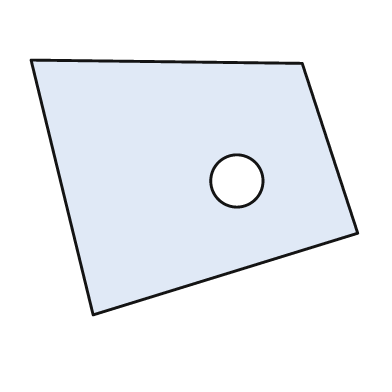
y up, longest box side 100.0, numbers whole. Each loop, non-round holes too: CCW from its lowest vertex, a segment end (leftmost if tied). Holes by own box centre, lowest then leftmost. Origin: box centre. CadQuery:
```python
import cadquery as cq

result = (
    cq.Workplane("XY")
    .moveTo(-31.0, -39.0)
    .lineTo(50.0, -14.0)
    .lineTo(33.0, 38.0)
    .lineTo(-50.0, 39.0)
    .close()
    .moveTo(13.0, 2.0)
    .circle(8.0)
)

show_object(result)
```